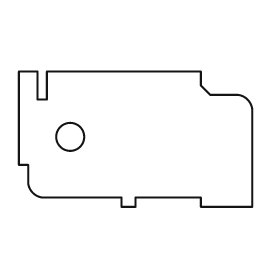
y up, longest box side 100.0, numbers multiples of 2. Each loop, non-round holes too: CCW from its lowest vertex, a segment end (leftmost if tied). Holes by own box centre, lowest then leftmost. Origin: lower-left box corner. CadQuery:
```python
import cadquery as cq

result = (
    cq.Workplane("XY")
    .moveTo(44.0, 0.0)
    .lineTo(50.0, 0.0)
    .lineTo(50.0, 4.0)
    .lineTo(78.0, 4.0)
    .lineTo(78.0, 0.0)
    .lineTo(100.0, 0.0)
    .lineTo(100.0, 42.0)
    .threePointArc((98.0, 46.0), (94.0, 48.0))
    .lineTo(82.0, 48.0)
    .lineTo(78.0, 52.0)
    .lineTo(78.0, 58.0)
    .lineTo(12.0, 58.0)
    .lineTo(12.0, 46.0)
    .lineTo(8.0, 46.0)
    .lineTo(8.0, 58.0)
    .lineTo(0.0, 58.0)
    .lineTo(0.0, 18.0)
    .lineTo(4.0, 18.0)
    .lineTo(4.0, 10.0)
    .threePointArc((6.0, 6.0), (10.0, 4.0))
    .lineTo(44.0, 4.0)
    .close()
    .moveTo(22.0, 30.0)
    .circle(6.0)
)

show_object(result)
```